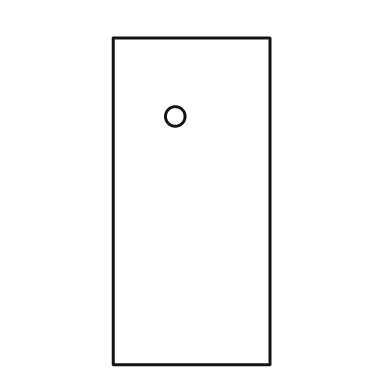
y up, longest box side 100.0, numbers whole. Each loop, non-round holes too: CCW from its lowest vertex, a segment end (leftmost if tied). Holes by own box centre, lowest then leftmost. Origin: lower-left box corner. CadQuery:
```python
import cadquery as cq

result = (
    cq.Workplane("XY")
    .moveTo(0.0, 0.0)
    .lineTo(48.0, 0.0)
    .lineTo(48.0, 100.0)
    .lineTo(0.0, 100.0)
    .close()
    .moveTo(19.0, 76.0)
    .circle(3.0)
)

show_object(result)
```